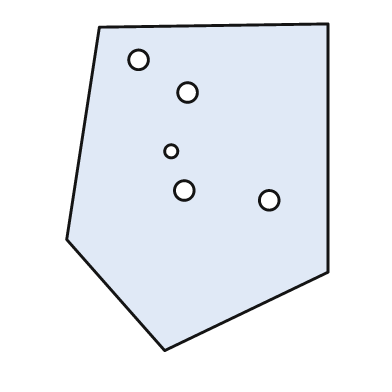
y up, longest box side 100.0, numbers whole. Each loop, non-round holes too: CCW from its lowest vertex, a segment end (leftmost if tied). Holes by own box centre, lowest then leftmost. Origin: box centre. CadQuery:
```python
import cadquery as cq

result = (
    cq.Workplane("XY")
    .moveTo(-10.0, -50.0)
    .lineTo(40.0, -26.0)
    .lineTo(40.0, 50.0)
    .lineTo(-30.0, 49.0)
    .lineTo(-40.0, -16.0)
    .close()
    .moveTo(22.0, -4.0)
    .circle(3.0)
    .moveTo(-4.0, -1.0)
    .circle(3.0)
    .moveTo(-8.0, 11.0)
    .circle(2.0)
    .moveTo(-3.0, 29.0)
    .circle(3.0)
    .moveTo(-18.0, 39.0)
    .circle(3.0)
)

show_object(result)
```